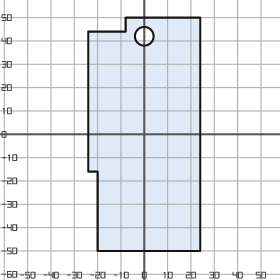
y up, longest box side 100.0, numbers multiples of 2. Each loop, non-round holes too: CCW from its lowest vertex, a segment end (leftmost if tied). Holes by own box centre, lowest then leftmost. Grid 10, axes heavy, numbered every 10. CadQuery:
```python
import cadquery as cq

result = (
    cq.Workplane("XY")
    .moveTo(-20.0, -50.0)
    .lineTo(24.0, -50.0)
    .lineTo(24.0, 50.0)
    .lineTo(-8.0, 50.0)
    .lineTo(-8.0, 44.0)
    .lineTo(-24.0, 44.0)
    .lineTo(-24.0, -16.0)
    .lineTo(-20.0, -16.0)
    .close()
    .moveTo(0.0, 42.0)
    .circle(4.0)
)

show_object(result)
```